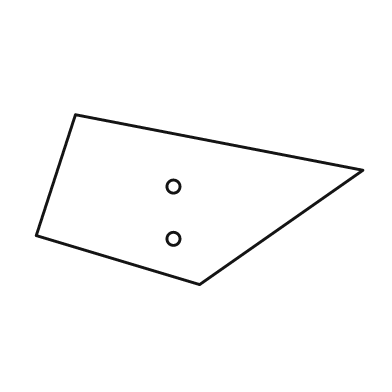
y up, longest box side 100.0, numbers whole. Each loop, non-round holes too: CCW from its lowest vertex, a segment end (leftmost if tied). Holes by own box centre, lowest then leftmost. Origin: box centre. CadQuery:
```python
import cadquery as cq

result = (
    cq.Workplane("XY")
    .moveTo(0.0, -26.0)
    .lineTo(50.0, 9.0)
    .lineTo(-38.0, 26.0)
    .lineTo(-50.0, -11.0)
    .close()
    .moveTo(-8.0, -12.0)
    .circle(2.0)
    .moveTo(-8.0, 4.0)
    .circle(2.0)
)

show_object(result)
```